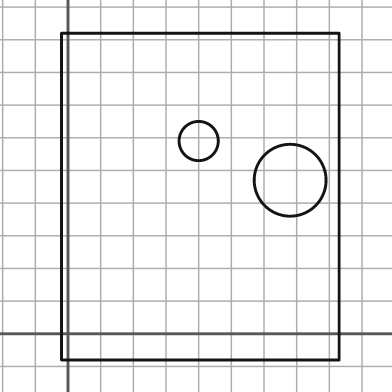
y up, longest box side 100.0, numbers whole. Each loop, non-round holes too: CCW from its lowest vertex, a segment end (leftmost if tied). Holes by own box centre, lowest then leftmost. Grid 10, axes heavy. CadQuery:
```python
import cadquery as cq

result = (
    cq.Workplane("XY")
    .moveTo(-2.0, -8.0)
    .lineTo(83.0, -8.0)
    .lineTo(83.0, 92.0)
    .lineTo(-2.0, 92.0)
    .close()
    .moveTo(68.0, 47.0)
    .circle(11.0)
    .moveTo(40.0, 59.0)
    .circle(6.0)
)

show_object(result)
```